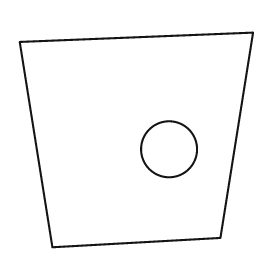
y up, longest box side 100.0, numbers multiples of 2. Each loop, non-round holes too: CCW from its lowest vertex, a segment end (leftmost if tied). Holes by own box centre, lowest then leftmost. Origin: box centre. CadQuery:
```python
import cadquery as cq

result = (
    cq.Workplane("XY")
    .moveTo(-36.0, -46.0)
    .lineTo(36.0, -42.0)
    .lineTo(50.0, 46.0)
    .lineTo(-50.0, 42.0)
    .close()
    .moveTo(14.0, -4.0)
    .circle(12.0)
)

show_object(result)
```